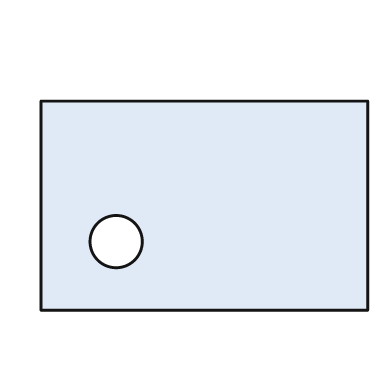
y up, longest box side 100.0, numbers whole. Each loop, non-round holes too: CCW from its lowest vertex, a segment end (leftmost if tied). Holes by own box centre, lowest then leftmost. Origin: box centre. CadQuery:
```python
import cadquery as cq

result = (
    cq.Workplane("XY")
    .moveTo(-50.0, -32.0)
    .lineTo(50.0, -32.0)
    .lineTo(50.0, 32.0)
    .lineTo(-50.0, 32.0)
    .close()
    .moveTo(-27.0, -11.0)
    .circle(8.0)
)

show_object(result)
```